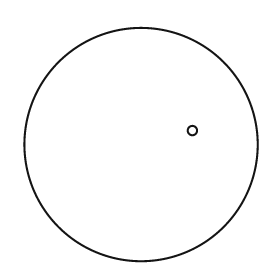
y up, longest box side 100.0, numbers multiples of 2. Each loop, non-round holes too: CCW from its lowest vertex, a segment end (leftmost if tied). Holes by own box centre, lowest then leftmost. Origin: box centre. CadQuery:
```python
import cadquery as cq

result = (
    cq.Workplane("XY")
    .moveTo(0.0, 0.0)
    .circle(50.0)
    .moveTo(22.0, 6.0)
    .circle(2.0)
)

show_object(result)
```